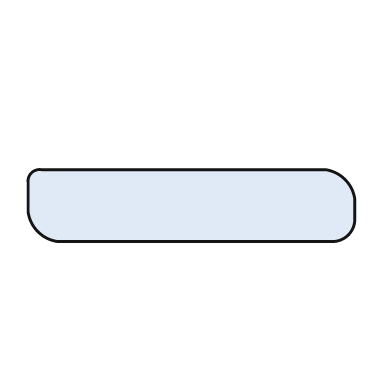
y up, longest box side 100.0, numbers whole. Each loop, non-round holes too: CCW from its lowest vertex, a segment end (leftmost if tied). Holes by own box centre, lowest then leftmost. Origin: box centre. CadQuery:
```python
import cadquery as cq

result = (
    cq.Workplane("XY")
    .moveTo(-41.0, -11.0)
    .lineTo(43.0, -11.0)
    .threePointArc((48.0, -9.0), (50.0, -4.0))
    .lineTo(50.0, 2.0)
    .threePointArc((47.0, 8.0), (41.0, 11.0))
    .lineTo(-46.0, 11.0)
    .threePointArc((-49.0, 10.0), (-50.0, 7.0))
    .lineTo(-50.0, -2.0)
    .threePointArc((-47.0, -8.0), (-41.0, -11.0))
    .close()
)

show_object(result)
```